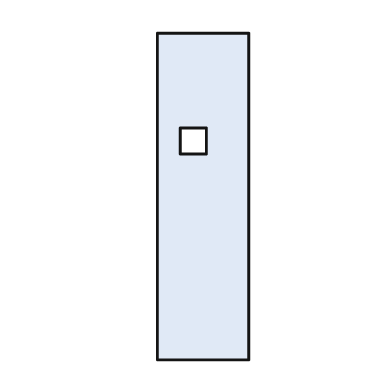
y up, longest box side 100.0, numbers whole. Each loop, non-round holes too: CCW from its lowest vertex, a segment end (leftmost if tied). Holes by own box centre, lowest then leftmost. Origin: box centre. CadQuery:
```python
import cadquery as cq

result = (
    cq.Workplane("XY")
    .moveTo(-14.0, -50.0)
    .lineTo(14.0, -50.0)
    .lineTo(14.0, 50.0)
    .lineTo(-14.0, 50.0)
    .close()
    .moveTo(-7.0, 13.0)
    .lineTo(1.0, 13.0)
    .lineTo(1.0, 21.0)
    .lineTo(-7.0, 21.0)
    .close()
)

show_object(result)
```